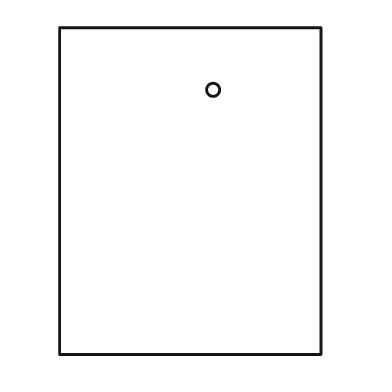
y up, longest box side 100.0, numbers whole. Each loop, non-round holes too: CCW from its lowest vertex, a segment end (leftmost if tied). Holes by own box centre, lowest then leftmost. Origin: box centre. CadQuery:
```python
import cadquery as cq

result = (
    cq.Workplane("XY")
    .moveTo(-40.0, -50.0)
    .lineTo(40.0, -50.0)
    .lineTo(40.0, 50.0)
    .lineTo(-40.0, 50.0)
    .close()
    .moveTo(7.0, 31.0)
    .circle(2.0)
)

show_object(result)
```